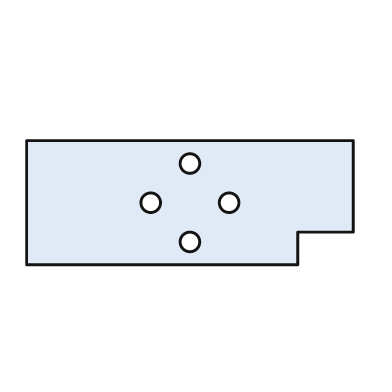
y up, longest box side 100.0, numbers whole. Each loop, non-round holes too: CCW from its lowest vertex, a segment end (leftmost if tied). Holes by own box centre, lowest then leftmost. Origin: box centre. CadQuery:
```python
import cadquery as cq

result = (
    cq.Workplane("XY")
    .moveTo(-50.0, -19.0)
    .lineTo(33.0, -19.0)
    .lineTo(33.0, -9.0)
    .lineTo(50.0, -9.0)
    .lineTo(50.0, 19.0)
    .lineTo(-50.0, 19.0)
    .close()
    .moveTo(0.0, -12.0)
    .circle(3.0)
    .moveTo(-12.0, 0.0)
    .circle(3.0)
    .moveTo(12.0, 0.0)
    .circle(3.0)
    .moveTo(0.0, 12.0)
    .circle(3.0)
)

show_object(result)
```